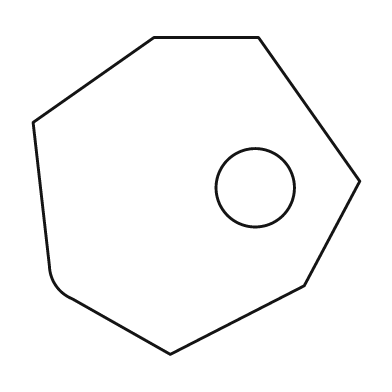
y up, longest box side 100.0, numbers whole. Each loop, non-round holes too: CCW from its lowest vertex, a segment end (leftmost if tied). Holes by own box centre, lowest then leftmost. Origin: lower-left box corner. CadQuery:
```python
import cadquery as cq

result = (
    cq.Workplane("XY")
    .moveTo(42.0, 0.0)
    .lineTo(83.0, 21.0)
    .lineTo(100.0, 53.0)
    .lineTo(69.0, 97.0)
    .lineTo(37.0, 97.0)
    .lineTo(0.0, 71.0)
    .lineTo(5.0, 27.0)
    .threePointArc((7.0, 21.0), (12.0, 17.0))
    .close()
    .moveTo(68.0, 51.0)
    .circle(12.0)
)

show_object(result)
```